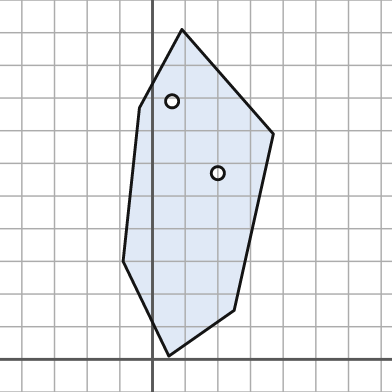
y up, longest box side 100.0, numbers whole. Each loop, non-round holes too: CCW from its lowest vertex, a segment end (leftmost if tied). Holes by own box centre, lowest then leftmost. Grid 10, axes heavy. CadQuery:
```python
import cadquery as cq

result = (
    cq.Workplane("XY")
    .moveTo(5.0, 1.0)
    .lineTo(25.0, 15.0)
    .lineTo(37.0, 69.0)
    .lineTo(9.0, 101.0)
    .lineTo(-4.0, 77.0)
    .lineTo(-9.0, 30.0)
    .close()
    .moveTo(20.0, 57.0)
    .circle(2.0)
    .moveTo(6.0, 79.0)
    .circle(2.0)
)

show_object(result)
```